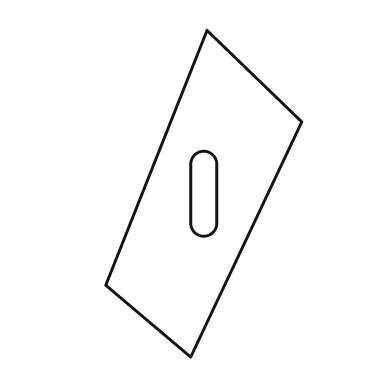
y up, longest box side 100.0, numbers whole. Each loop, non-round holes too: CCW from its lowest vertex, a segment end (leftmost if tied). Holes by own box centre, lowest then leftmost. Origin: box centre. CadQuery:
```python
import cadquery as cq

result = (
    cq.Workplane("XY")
    .moveTo(-4.0, -50.0)
    .lineTo(30.0, 22.0)
    .lineTo(1.0, 50.0)
    .lineTo(-30.0, -28.0)
    .close()
    .moveTo(-4.0, -9.0)
    .threePointArc((0.0, -13.0), (4.0, -9.0))
    .lineTo(4.0, 9.0)
    .threePointArc((0.0, 13.0), (-4.0, 9.0))
    .close()
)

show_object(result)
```